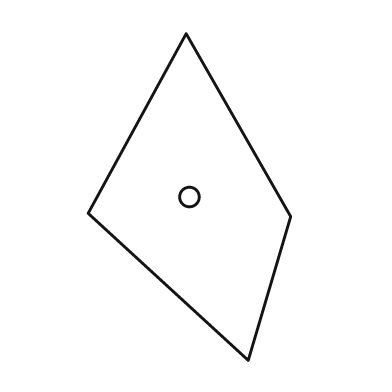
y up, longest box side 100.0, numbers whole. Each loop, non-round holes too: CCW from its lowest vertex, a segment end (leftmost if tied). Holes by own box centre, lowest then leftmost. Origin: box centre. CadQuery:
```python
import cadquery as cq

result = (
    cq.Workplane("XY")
    .moveTo(18.0, -50.0)
    .lineTo(31.0, -6.0)
    .lineTo(-1.0, 50.0)
    .lineTo(-31.0, -5.0)
    .close()
    .moveTo(0.0, 0.0)
    .circle(3.0)
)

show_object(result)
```